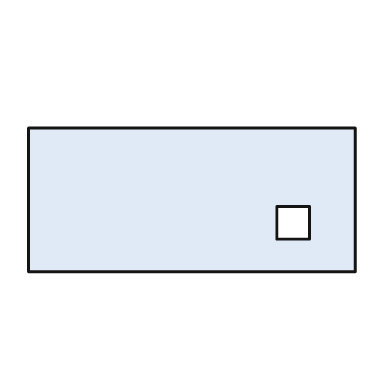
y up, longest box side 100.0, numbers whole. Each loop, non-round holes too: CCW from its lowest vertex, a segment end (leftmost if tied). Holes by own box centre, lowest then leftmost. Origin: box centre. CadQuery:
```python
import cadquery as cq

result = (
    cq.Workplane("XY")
    .moveTo(-50.0, -22.0)
    .lineTo(50.0, -22.0)
    .lineTo(50.0, 22.0)
    .lineTo(-50.0, 22.0)
    .close()
    .moveTo(26.0, -12.0)
    .lineTo(36.0, -12.0)
    .lineTo(36.0, -2.0)
    .lineTo(26.0, -2.0)
    .close()
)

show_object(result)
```